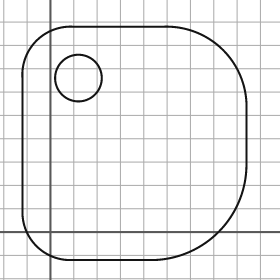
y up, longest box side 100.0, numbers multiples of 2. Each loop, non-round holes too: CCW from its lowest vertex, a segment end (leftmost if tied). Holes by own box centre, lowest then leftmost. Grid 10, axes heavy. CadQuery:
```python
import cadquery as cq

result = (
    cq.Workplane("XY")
    .moveTo(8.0, -12.0)
    .lineTo(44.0, -12.0)
    .threePointArc((72.0, 0.0), (84.0, 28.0))
    .lineTo(84.0, 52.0)
    .threePointArc((74.0, 78.0), (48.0, 88.0))
    .lineTo(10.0, 88.0)
    .threePointArc((-6.0, 82.0), (-12.0, 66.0))
    .lineTo(-12.0, 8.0)
    .threePointArc((-6.0, -6.0), (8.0, -12.0))
    .close()
    .moveTo(12.0, 66.0)
    .circle(10.0)
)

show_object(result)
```